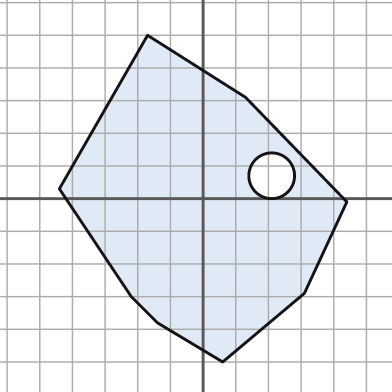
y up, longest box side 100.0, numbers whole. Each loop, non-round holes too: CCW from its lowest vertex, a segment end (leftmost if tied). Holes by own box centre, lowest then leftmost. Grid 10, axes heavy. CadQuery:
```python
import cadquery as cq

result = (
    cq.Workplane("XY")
    .moveTo(6.0, -50.0)
    .lineTo(31.0, -29.0)
    .lineTo(44.0, -1.0)
    .lineTo(13.0, 31.0)
    .lineTo(-17.0, 50.0)
    .lineTo(-44.0, 3.0)
    .lineTo(-22.0, -30.0)
    .lineTo(-14.0, -38.0)
    .close()
    .moveTo(21.0, 7.0)
    .circle(7.0)
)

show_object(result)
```